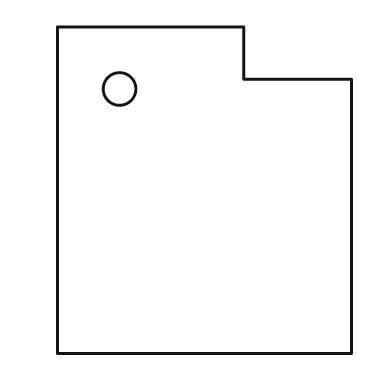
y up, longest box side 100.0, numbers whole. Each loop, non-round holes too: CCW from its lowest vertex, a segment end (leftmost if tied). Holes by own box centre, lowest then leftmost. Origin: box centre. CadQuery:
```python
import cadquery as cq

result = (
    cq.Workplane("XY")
    .moveTo(-45.0, -50.0)
    .lineTo(45.0, -50.0)
    .lineTo(45.0, 34.0)
    .lineTo(12.0, 34.0)
    .lineTo(12.0, 50.0)
    .lineTo(-45.0, 50.0)
    .close()
    .moveTo(-26.0, 31.0)
    .circle(5.0)
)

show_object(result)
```